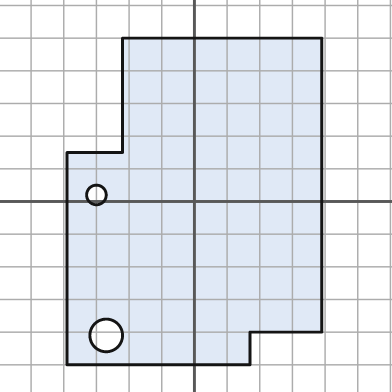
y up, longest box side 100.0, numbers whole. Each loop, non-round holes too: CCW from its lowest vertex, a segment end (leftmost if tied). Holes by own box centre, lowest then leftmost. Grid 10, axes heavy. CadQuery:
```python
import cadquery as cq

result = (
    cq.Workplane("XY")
    .moveTo(-39.0, -50.0)
    .lineTo(17.0, -50.0)
    .lineTo(17.0, -40.0)
    .lineTo(39.0, -40.0)
    .lineTo(39.0, 50.0)
    .lineTo(-22.0, 50.0)
    .lineTo(-22.0, 15.0)
    .lineTo(-39.0, 15.0)
    .close()
    .moveTo(-27.0, -41.0)
    .circle(5.0)
    .moveTo(-30.0, 2.0)
    .circle(3.0)
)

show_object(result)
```